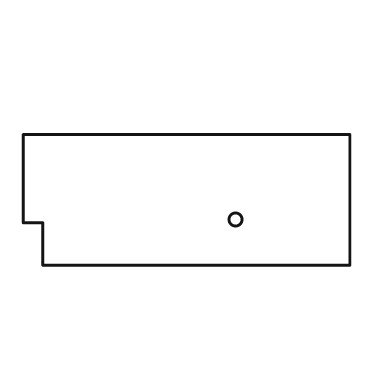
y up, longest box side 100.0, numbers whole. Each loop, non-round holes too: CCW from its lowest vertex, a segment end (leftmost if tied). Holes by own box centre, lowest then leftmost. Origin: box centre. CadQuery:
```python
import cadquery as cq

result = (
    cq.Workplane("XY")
    .moveTo(-44.0, -20.0)
    .lineTo(50.0, -20.0)
    .lineTo(50.0, 20.0)
    .lineTo(-50.0, 20.0)
    .lineTo(-50.0, -7.0)
    .lineTo(-44.0, -7.0)
    .close()
    .moveTo(15.0, -6.0)
    .circle(2.0)
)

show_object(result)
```